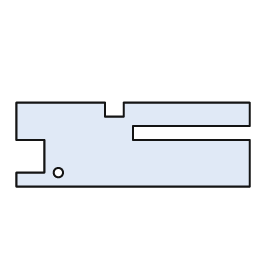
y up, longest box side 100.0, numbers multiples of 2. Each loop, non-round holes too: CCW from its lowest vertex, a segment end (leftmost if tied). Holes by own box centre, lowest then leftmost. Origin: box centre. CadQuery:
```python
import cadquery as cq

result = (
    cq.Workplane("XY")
    .moveTo(-50.0, -18.0)
    .lineTo(50.0, -18.0)
    .lineTo(50.0, 2.0)
    .lineTo(0.0, 2.0)
    .lineTo(0.0, 8.0)
    .lineTo(50.0, 8.0)
    .lineTo(50.0, 18.0)
    .lineTo(-4.0, 18.0)
    .lineTo(-4.0, 12.0)
    .lineTo(-12.0, 12.0)
    .lineTo(-12.0, 18.0)
    .lineTo(-50.0, 18.0)
    .lineTo(-50.0, 2.0)
    .lineTo(-38.0, 2.0)
    .lineTo(-38.0, -12.0)
    .lineTo(-50.0, -12.0)
    .close()
    .moveTo(-32.0, -12.0)
    .circle(2.0)
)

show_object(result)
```